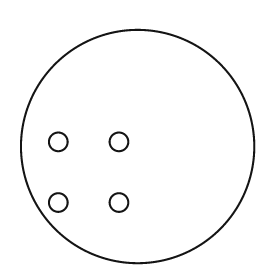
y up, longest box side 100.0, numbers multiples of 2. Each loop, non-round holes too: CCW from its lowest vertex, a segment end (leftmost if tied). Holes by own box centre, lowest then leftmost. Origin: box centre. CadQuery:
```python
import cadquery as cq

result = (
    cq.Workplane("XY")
    .moveTo(0.0, 0.0)
    .circle(50.0)
    .moveTo(-34.0, -24.0)
    .circle(4.0)
    .moveTo(-8.0, -24.0)
    .circle(4.0)
    .moveTo(-34.0, 2.0)
    .circle(4.0)
    .moveTo(-8.0, 2.0)
    .circle(4.0)
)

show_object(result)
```